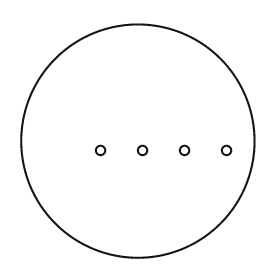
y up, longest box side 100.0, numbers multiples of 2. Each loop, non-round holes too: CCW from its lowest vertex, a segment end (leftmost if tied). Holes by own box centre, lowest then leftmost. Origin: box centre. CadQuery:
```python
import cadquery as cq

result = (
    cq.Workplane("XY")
    .moveTo(0.0, 0.0)
    .circle(50.0)
    .moveTo(-16.0, -4.0)
    .circle(2.0)
    .moveTo(2.0, -4.0)
    .circle(2.0)
    .moveTo(20.0, -4.0)
    .circle(2.0)
    .moveTo(38.0, -4.0)
    .circle(2.0)
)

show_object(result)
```